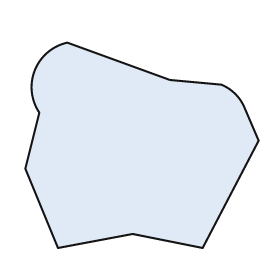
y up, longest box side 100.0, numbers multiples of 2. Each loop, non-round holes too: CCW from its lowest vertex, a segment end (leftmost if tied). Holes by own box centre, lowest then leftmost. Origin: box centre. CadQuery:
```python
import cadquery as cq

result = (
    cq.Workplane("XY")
    .moveTo(-36.0, -44.0)
    .lineTo(-4.0, -38.0)
    .lineTo(26.0, -44.0)
    .lineTo(50.0, 2.0)
    .lineTo(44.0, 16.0)
    .threePointArc((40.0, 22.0), (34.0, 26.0))
    .lineTo(12.0, 28.0)
    .lineTo(-32.0, 44.0)
    .threePointArc((-46.0, 32.0), (-44.0, 14.0))
    .lineTo(-50.0, -10.0)
    .close()
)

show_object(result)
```